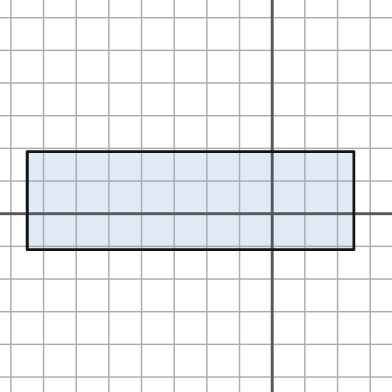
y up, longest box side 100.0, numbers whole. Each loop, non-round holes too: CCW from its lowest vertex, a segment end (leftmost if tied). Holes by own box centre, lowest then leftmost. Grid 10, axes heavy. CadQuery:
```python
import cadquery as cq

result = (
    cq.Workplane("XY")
    .moveTo(-75.0, -11.0)
    .lineTo(25.0, -11.0)
    .lineTo(25.0, 19.0)
    .lineTo(-75.0, 19.0)
    .close()
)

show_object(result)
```